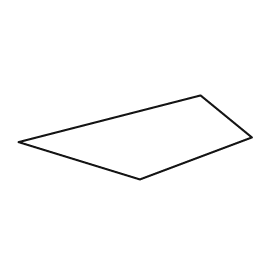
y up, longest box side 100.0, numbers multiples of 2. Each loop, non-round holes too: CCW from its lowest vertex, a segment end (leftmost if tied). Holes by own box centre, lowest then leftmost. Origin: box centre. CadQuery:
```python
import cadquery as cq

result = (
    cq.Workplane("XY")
    .moveTo(2.0, -18.0)
    .lineTo(50.0, 0.0)
    .lineTo(28.0, 18.0)
    .lineTo(-50.0, -2.0)
    .close()
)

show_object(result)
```